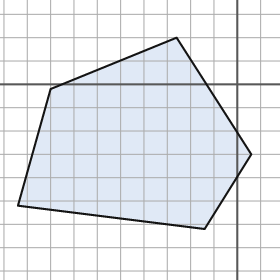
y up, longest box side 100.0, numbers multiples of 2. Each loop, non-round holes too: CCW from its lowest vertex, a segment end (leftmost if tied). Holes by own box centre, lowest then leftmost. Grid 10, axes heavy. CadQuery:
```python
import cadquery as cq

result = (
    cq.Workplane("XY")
    .moveTo(-14.0, -62.0)
    .lineTo(6.0, -30.0)
    .lineTo(-26.0, 20.0)
    .lineTo(-80.0, -2.0)
    .lineTo(-94.0, -52.0)
    .close()
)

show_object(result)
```